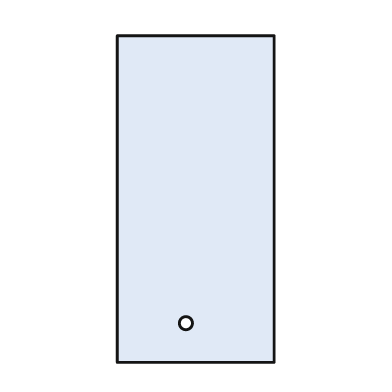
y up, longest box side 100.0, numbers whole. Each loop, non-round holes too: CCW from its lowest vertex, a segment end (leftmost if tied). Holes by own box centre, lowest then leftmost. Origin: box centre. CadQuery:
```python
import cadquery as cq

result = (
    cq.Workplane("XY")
    .moveTo(-24.0, -50.0)
    .lineTo(24.0, -50.0)
    .lineTo(24.0, 50.0)
    .lineTo(-24.0, 50.0)
    .close()
    .moveTo(-3.0, -38.0)
    .circle(2.0)
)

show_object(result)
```